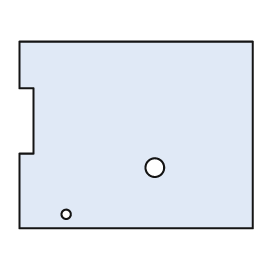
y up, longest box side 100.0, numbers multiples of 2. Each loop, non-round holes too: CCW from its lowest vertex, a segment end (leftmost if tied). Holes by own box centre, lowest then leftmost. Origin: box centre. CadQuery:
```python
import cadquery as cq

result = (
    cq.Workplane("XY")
    .moveTo(-50.0, -40.0)
    .lineTo(50.0, -40.0)
    .lineTo(50.0, 40.0)
    .lineTo(-50.0, 40.0)
    .lineTo(-50.0, 20.0)
    .lineTo(-44.0, 20.0)
    .lineTo(-44.0, -8.0)
    .lineTo(-50.0, -8.0)
    .close()
    .moveTo(-30.0, -34.0)
    .circle(2.0)
    .moveTo(8.0, -14.0)
    .circle(4.0)
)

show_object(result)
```